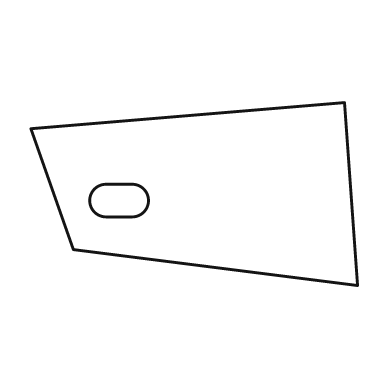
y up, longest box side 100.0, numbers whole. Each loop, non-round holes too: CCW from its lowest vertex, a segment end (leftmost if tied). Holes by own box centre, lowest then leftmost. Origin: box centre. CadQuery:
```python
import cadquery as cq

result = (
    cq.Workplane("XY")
    .moveTo(50.0, -28.0)
    .lineTo(46.0, 28.0)
    .lineTo(-50.0, 20.0)
    .lineTo(-37.0, -17.0)
    .close()
    .moveTo(-27.0, -7.0)
    .lineTo(-19.0, -7.0)
    .threePointArc((-14.0, -2.0), (-19.0, 3.0))
    .lineTo(-27.0, 3.0)
    .threePointArc((-32.0, -2.0), (-27.0, -7.0))
    .close()
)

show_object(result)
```